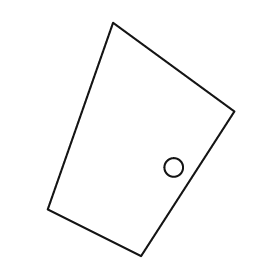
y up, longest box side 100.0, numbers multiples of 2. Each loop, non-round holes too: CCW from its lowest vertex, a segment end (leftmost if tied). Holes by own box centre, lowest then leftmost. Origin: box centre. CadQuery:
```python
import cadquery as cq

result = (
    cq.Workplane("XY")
    .moveTo(0.0, -50.0)
    .lineTo(40.0, 12.0)
    .lineTo(-12.0, 50.0)
    .lineTo(-40.0, -30.0)
    .close()
    .moveTo(14.0, -12.0)
    .circle(4.0)
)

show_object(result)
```